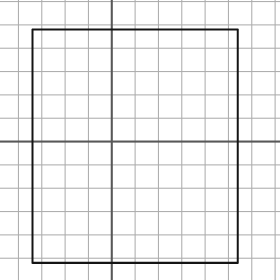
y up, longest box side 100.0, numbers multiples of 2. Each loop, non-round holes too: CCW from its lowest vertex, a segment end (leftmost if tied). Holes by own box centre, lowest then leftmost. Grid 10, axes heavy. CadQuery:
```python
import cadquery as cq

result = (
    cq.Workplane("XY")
    .moveTo(-34.0, -52.0)
    .lineTo(54.0, -52.0)
    .lineTo(54.0, 48.0)
    .lineTo(-34.0, 48.0)
    .close()
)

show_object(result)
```